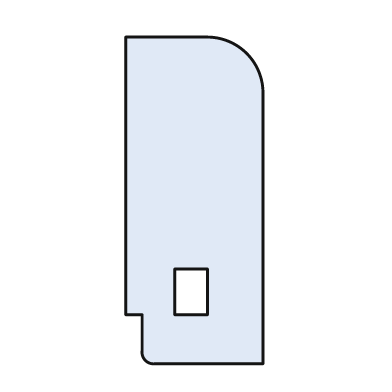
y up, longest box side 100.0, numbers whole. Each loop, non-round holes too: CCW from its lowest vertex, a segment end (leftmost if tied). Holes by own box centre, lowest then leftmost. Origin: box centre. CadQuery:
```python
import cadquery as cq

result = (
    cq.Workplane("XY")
    .moveTo(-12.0, -50.0)
    .lineTo(21.0, -50.0)
    .lineTo(21.0, 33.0)
    .threePointArc((16.0, 45.0), (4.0, 50.0))
    .lineTo(-21.0, 50.0)
    .lineTo(-21.0, -35.0)
    .lineTo(-16.0, -35.0)
    .lineTo(-16.0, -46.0)
    .threePointArc((-15.0, -49.0), (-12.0, -50.0))
    .close()
    .moveTo(-6.0, -35.0)
    .lineTo(4.0, -35.0)
    .lineTo(4.0, -21.0)
    .lineTo(-6.0, -21.0)
    .close()
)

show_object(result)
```